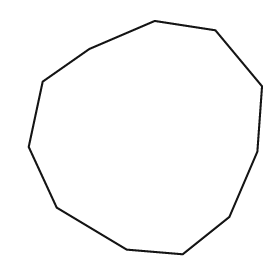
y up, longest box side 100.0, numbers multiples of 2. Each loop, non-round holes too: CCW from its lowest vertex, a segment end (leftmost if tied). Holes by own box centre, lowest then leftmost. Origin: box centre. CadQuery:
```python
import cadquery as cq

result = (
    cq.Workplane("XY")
    .moveTo(16.0, -50.0)
    .lineTo(36.0, -34.0)
    .lineTo(48.0, -6.0)
    .lineTo(50.0, 22.0)
    .lineTo(30.0, 46.0)
    .lineTo(4.0, 50.0)
    .lineTo(-24.0, 38.0)
    .lineTo(-44.0, 24.0)
    .lineTo(-50.0, -4.0)
    .lineTo(-38.0, -30.0)
    .lineTo(-8.0, -48.0)
    .close()
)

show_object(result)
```